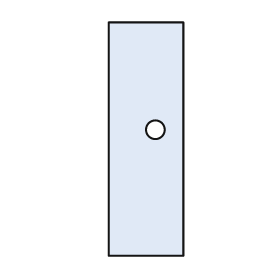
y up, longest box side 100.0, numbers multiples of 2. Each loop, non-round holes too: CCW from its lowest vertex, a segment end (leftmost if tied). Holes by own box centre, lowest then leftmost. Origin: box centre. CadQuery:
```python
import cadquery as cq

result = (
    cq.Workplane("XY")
    .moveTo(-16.0, -50.0)
    .lineTo(16.0, -50.0)
    .lineTo(16.0, 50.0)
    .lineTo(-16.0, 50.0)
    .close()
    .moveTo(4.0, 4.0)
    .circle(4.0)
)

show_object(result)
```